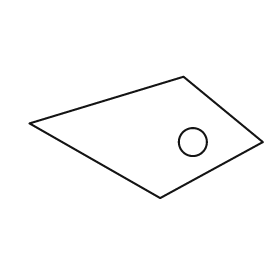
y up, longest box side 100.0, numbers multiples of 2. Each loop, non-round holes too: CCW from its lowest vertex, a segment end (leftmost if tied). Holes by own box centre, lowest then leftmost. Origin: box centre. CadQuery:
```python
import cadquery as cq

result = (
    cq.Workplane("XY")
    .moveTo(6.0, -26.0)
    .lineTo(50.0, -2.0)
    .lineTo(16.0, 26.0)
    .lineTo(-50.0, 6.0)
    .close()
    .moveTo(20.0, -2.0)
    .circle(6.0)
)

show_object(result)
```